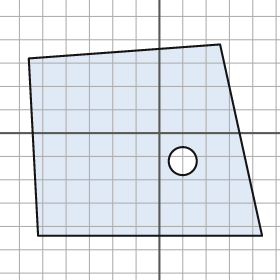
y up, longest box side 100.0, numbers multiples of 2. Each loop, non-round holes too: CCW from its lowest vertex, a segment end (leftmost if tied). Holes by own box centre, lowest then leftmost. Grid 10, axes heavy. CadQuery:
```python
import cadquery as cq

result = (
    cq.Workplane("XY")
    .moveTo(-52.0, -44.0)
    .lineTo(44.0, -44.0)
    .lineTo(26.0, 38.0)
    .lineTo(-56.0, 32.0)
    .close()
    .moveTo(10.0, -12.0)
    .circle(6.0)
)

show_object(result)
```